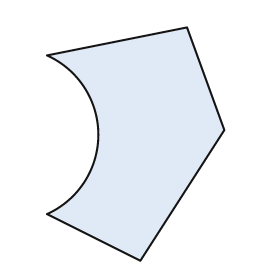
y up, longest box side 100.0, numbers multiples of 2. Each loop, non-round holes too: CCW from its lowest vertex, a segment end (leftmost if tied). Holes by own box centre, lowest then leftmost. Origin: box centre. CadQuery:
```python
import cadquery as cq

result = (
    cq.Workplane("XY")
    .moveTo(2.0, -50.0)
    .lineTo(38.0, 6.0)
    .lineTo(22.0, 50.0)
    .lineTo(-38.0, 38.0)
    .threePointArc((-16.0, 4.0), (-38.0, -30.0))
    .close()
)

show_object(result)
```